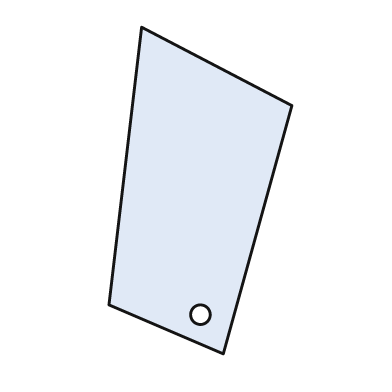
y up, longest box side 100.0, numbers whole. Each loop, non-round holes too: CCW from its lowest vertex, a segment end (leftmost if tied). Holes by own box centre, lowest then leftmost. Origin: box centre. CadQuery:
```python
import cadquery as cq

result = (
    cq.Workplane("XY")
    .moveTo(7.0, -50.0)
    .lineTo(28.0, 26.0)
    .lineTo(-18.0, 50.0)
    .lineTo(-28.0, -35.0)
    .close()
    .moveTo(0.0, -38.0)
    .circle(3.0)
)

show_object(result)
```